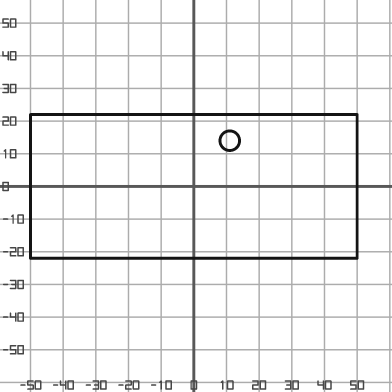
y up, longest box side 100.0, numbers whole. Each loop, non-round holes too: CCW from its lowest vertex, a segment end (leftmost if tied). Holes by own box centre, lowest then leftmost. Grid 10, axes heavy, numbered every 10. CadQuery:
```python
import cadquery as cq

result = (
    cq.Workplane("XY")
    .moveTo(-50.0, -22.0)
    .lineTo(50.0, -22.0)
    .lineTo(50.0, 22.0)
    .lineTo(-50.0, 22.0)
    .close()
    .moveTo(11.0, 14.0)
    .circle(3.0)
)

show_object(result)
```